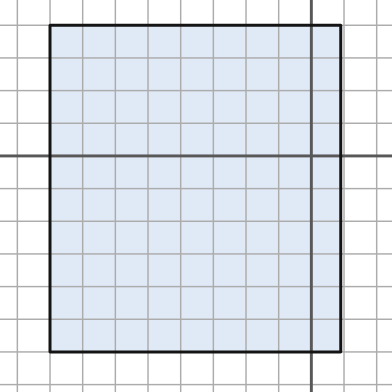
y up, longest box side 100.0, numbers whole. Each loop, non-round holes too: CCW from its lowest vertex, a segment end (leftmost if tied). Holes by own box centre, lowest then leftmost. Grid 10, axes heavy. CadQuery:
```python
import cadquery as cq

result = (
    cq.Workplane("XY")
    .moveTo(-80.0, -60.0)
    .lineTo(9.0, -60.0)
    .lineTo(9.0, 40.0)
    .lineTo(-80.0, 40.0)
    .close()
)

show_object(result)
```